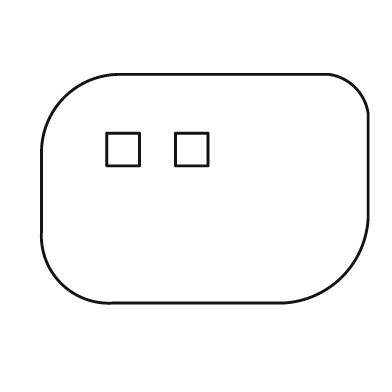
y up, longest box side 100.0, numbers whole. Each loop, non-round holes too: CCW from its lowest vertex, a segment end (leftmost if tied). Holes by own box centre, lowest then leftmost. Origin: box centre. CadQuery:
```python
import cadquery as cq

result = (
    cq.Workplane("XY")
    .moveTo(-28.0, -35.0)
    .lineTo(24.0, -35.0)
    .threePointArc((42.0, -27.0), (50.0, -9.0))
    .lineTo(50.0, 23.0)
    .threePointArc((46.0, 31.0), (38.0, 35.0))
    .lineTo(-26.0, 35.0)
    .threePointArc((-43.0, 28.0), (-50.0, 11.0))
    .lineTo(-50.0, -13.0)
    .threePointArc((-44.0, -29.0), (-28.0, -35.0))
    .close()
    .moveTo(-30.0, 7.0)
    .lineTo(-20.0, 7.0)
    .lineTo(-20.0, 17.0)
    .lineTo(-30.0, 17.0)
    .close()
    .moveTo(-9.0, 7.0)
    .lineTo(1.0, 7.0)
    .lineTo(1.0, 17.0)
    .lineTo(-9.0, 17.0)
    .close()
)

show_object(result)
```